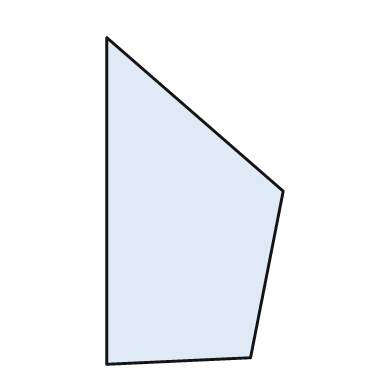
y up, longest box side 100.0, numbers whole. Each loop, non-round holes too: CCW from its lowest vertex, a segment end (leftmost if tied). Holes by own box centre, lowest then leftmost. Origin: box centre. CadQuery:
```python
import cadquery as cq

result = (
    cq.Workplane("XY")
    .moveTo(-27.0, -50.0)
    .lineTo(17.0, -48.0)
    .lineTo(27.0, 3.0)
    .lineTo(-27.0, 50.0)
    .close()
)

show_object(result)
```